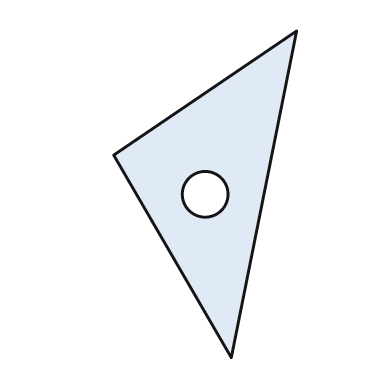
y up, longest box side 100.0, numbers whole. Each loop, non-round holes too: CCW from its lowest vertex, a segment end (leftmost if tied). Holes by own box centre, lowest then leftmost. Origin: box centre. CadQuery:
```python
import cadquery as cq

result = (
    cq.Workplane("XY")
    .moveTo(8.0, -50.0)
    .lineTo(28.0, 50.0)
    .lineTo(-28.0, 12.0)
    .close()
    .moveTo(0.0, 0.0)
    .circle(7.0)
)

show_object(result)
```